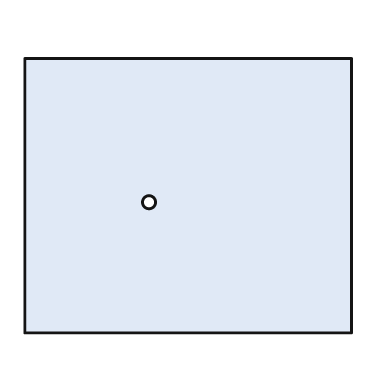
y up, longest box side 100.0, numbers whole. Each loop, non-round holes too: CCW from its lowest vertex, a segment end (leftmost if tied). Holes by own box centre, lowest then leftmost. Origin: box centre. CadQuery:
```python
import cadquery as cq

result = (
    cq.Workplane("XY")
    .moveTo(-50.0, -42.0)
    .lineTo(50.0, -42.0)
    .lineTo(50.0, 42.0)
    .lineTo(-50.0, 42.0)
    .close()
    .moveTo(-12.0, -2.0)
    .circle(2.0)
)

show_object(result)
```